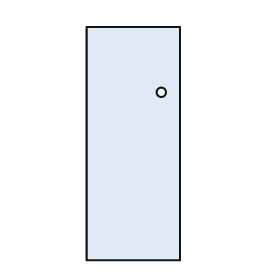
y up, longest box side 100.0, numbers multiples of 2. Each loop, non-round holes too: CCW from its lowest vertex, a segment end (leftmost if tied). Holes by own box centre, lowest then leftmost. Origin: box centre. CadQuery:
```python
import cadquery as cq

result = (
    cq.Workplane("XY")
    .moveTo(-20.0, -50.0)
    .lineTo(20.0, -50.0)
    .lineTo(20.0, 50.0)
    .lineTo(-20.0, 50.0)
    .close()
    .moveTo(12.0, 22.0)
    .circle(2.0)
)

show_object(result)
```